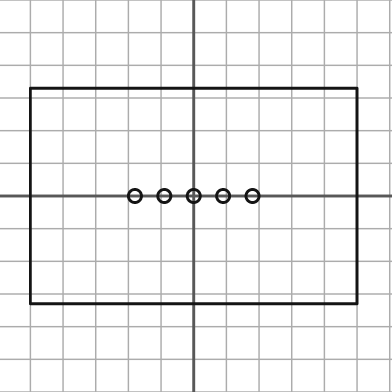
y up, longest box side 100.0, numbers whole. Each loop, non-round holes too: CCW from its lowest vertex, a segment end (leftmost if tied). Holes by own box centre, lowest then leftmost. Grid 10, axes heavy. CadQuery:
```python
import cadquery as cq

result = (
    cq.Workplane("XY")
    .moveTo(-50.0, -33.0)
    .lineTo(50.0, -33.0)
    .lineTo(50.0, 33.0)
    .lineTo(-50.0, 33.0)
    .close()
    .moveTo(-18.0, 0.0)
    .circle(2.0)
    .moveTo(-9.0, 0.0)
    .circle(2.0)
    .moveTo(0.0, 0.0)
    .circle(2.0)
    .moveTo(9.0, 0.0)
    .circle(2.0)
    .moveTo(18.0, 0.0)
    .circle(2.0)
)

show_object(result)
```